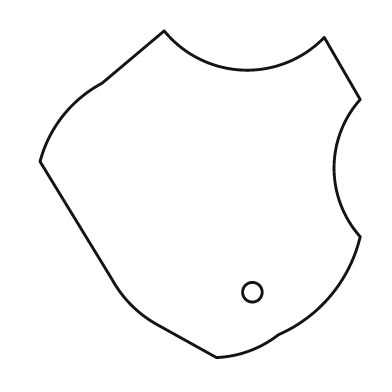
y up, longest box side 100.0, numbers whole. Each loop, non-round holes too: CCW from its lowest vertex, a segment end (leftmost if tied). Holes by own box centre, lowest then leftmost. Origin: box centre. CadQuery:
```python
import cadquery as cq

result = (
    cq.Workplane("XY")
    .moveTo(5.0, -50.0)
    .threePointArc((15.0, -48.0), (24.0, -43.0))
    .threePointArc((40.0, -31.0), (49.0, -13.0))
    .threePointArc((41.0, 8.0), (49.0, 29.0))
    .lineTo(38.0, 48.0)
    .threePointArc((13.0, 38.0), (-11.0, 50.0))
    .lineTo(-30.0, 34.0)
    .threePointArc((-42.0, 24.0), (-49.0, 10.0))
    .lineTo(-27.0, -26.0)
    .threePointArc((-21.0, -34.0), (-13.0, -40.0))
    .close()
    .moveTo(16.0, -30.0)
    .circle(3.0)
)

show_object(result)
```